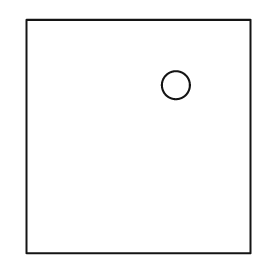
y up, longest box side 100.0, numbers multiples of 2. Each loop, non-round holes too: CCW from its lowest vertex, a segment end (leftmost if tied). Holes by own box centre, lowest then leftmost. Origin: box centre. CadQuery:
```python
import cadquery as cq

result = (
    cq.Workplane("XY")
    .moveTo(-48.0, -50.0)
    .lineTo(48.0, -50.0)
    .lineTo(48.0, 50.0)
    .lineTo(-48.0, 50.0)
    .close()
    .moveTo(16.0, 22.0)
    .circle(6.0)
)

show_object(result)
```